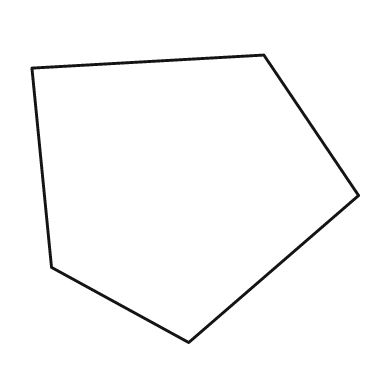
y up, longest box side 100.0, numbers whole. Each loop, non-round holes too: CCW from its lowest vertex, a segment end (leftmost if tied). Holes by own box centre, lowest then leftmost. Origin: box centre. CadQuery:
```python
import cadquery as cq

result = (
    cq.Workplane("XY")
    .moveTo(-2.0, -44.0)
    .lineTo(50.0, 1.0)
    .lineTo(21.0, 44.0)
    .lineTo(-50.0, 40.0)
    .lineTo(-44.0, -21.0)
    .close()
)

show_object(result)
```